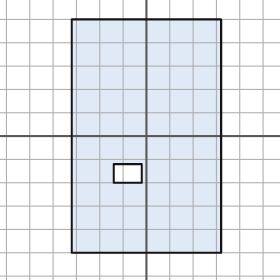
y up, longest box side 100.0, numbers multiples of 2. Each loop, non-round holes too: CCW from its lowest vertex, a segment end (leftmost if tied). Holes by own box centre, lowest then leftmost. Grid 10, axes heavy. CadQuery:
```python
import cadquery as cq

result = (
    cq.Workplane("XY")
    .moveTo(-32.0, -50.0)
    .lineTo(32.0, -50.0)
    .lineTo(32.0, 50.0)
    .lineTo(-32.0, 50.0)
    .close()
    .moveTo(-14.0, -20.0)
    .lineTo(-2.0, -20.0)
    .lineTo(-2.0, -12.0)
    .lineTo(-14.0, -12.0)
    .close()
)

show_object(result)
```